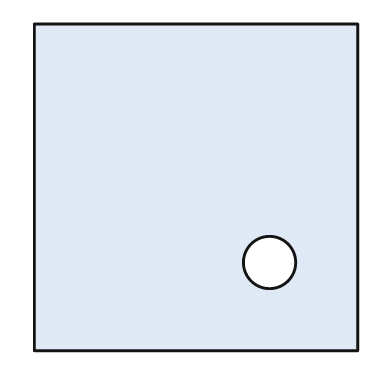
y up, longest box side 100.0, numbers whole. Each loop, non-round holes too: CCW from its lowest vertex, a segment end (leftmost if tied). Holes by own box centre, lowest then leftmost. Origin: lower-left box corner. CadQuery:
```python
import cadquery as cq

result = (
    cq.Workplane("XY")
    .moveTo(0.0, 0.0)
    .lineTo(99.0, 0.0)
    .lineTo(99.0, 100.0)
    .lineTo(0.0, 100.0)
    .close()
    .moveTo(72.0, 27.0)
    .circle(8.0)
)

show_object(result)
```